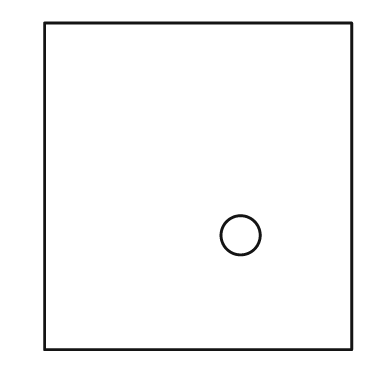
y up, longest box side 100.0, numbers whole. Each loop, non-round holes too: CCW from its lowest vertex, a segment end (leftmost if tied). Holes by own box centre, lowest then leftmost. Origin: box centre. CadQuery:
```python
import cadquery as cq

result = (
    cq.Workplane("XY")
    .moveTo(-47.0, -50.0)
    .lineTo(47.0, -50.0)
    .lineTo(47.0, 50.0)
    .lineTo(-47.0, 50.0)
    .close()
    .moveTo(13.0, -15.0)
    .circle(6.0)
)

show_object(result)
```